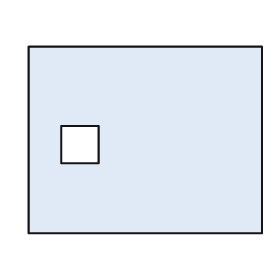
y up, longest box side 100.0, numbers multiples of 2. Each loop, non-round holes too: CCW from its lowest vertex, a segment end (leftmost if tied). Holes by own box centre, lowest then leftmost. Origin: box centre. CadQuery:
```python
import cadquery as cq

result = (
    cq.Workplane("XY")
    .moveTo(-50.0, -40.0)
    .lineTo(50.0, -40.0)
    .lineTo(50.0, 40.0)
    .lineTo(-50.0, 40.0)
    .close()
    .moveTo(-36.0, -10.0)
    .lineTo(-20.0, -10.0)
    .lineTo(-20.0, 6.0)
    .lineTo(-36.0, 6.0)
    .close()
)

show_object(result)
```